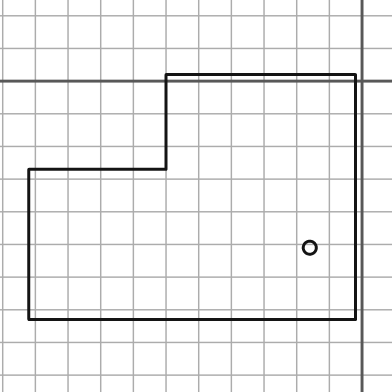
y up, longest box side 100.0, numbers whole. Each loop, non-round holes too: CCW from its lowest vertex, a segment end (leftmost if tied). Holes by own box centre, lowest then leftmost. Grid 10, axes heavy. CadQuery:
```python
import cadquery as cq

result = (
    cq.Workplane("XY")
    .moveTo(-102.0, -73.0)
    .lineTo(-2.0, -73.0)
    .lineTo(-2.0, 2.0)
    .lineTo(-60.0, 2.0)
    .lineTo(-60.0, -27.0)
    .lineTo(-102.0, -27.0)
    .close()
    .moveTo(-16.0, -51.0)
    .circle(2.0)
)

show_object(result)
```